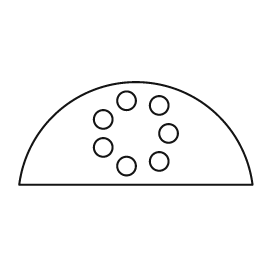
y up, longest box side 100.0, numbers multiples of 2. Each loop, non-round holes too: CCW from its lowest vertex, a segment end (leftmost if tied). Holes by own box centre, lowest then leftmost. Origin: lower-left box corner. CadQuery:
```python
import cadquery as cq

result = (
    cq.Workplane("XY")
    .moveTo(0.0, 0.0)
    .lineTo(100.0, 0.0)
    .threePointArc((50.0, 44.0), (0.0, 0.0))
    .close()
    .moveTo(46.0, 8.0)
    .circle(4.0)
    .moveTo(60.0, 10.0)
    .circle(4.0)
    .moveTo(36.0, 16.0)
    .circle(4.0)
    .moveTo(64.0, 22.0)
    .circle(4.0)
    .moveTo(36.0, 28.0)
    .circle(4.0)
    .moveTo(60.0, 34.0)
    .circle(4.0)
    .moveTo(46.0, 36.0)
    .circle(4.0)
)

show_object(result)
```